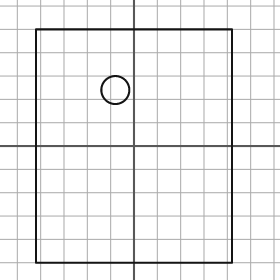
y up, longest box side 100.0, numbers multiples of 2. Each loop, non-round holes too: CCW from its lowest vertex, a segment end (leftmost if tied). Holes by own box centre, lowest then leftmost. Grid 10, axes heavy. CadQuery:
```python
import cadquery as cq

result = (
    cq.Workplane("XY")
    .moveTo(-42.0, -50.0)
    .lineTo(42.0, -50.0)
    .lineTo(42.0, 50.0)
    .lineTo(-42.0, 50.0)
    .close()
    .moveTo(-8.0, 24.0)
    .circle(6.0)
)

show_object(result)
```